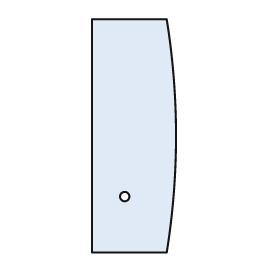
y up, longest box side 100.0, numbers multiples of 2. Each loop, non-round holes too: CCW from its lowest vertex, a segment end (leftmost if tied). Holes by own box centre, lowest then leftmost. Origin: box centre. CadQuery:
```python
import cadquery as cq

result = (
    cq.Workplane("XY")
    .moveTo(-18.0, -50.0)
    .lineTo(14.0, -50.0)
    .threePointArc((18.0, 0.0), (14.0, 50.0))
    .lineTo(-18.0, 50.0)
    .close()
    .moveTo(-4.0, -26.0)
    .circle(2.0)
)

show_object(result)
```